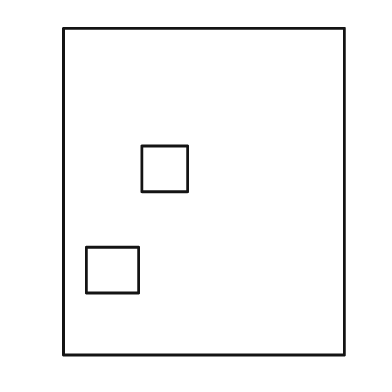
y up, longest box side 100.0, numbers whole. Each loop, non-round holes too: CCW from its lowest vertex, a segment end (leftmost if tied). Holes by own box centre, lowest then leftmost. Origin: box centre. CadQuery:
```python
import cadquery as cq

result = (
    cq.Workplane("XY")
    .moveTo(-43.0, -50.0)
    .lineTo(43.0, -50.0)
    .lineTo(43.0, 50.0)
    .lineTo(-43.0, 50.0)
    .close()
    .moveTo(-36.0, -31.0)
    .lineTo(-20.0, -31.0)
    .lineTo(-20.0, -17.0)
    .lineTo(-36.0, -17.0)
    .close()
    .moveTo(-19.0, 0.0)
    .lineTo(-5.0, 0.0)
    .lineTo(-5.0, 14.0)
    .lineTo(-19.0, 14.0)
    .close()
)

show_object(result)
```